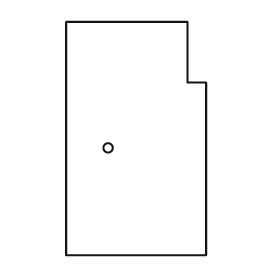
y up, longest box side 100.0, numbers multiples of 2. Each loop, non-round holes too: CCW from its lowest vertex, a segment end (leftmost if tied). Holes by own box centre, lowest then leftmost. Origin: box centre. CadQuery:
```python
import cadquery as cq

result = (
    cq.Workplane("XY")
    .moveTo(-30.0, -50.0)
    .lineTo(30.0, -50.0)
    .lineTo(30.0, 24.0)
    .lineTo(22.0, 24.0)
    .lineTo(22.0, 50.0)
    .lineTo(-30.0, 50.0)
    .close()
    .moveTo(-12.0, -4.0)
    .circle(2.0)
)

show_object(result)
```